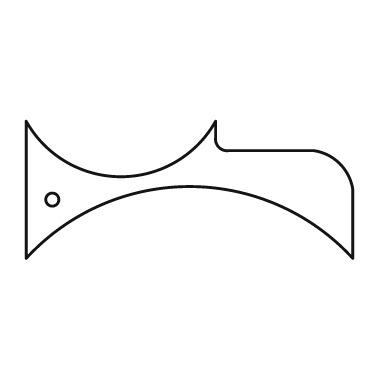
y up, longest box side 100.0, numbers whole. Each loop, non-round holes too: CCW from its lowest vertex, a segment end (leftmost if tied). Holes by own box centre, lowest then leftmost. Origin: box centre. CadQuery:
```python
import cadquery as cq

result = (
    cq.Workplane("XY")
    .moveTo(-50.0, -21.0)
    .threePointArc((0.0, 1.0), (50.0, -21.0))
    .lineTo(50.0, 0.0)
    .threePointArc((46.0, 8.0), (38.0, 12.0))
    .lineTo(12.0, 12.0)
    .threePointArc((9.0, 13.0), (8.0, 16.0))
    .lineTo(8.0, 21.0)
    .threePointArc((-21.0, 4.0), (-50.0, 21.0))
    .close()
    .moveTo(-42.0, -3.0)
    .circle(2.0)
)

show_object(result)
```